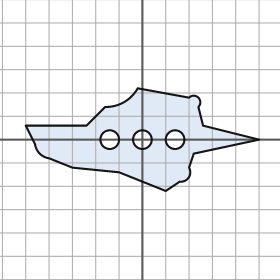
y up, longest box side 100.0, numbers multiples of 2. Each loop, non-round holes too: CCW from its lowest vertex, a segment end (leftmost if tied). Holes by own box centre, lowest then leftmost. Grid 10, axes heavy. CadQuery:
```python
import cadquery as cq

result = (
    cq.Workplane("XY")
    .moveTo(10.0, -22.0)
    .lineTo(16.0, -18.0)
    .threePointArc((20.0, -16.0), (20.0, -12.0))
    .lineTo(22.0, -6.0)
    .lineTo(50.0, 0.0)
    .lineTo(26.0, 6.0)
    .lineTo(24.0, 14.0)
    .threePointArc((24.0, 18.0), (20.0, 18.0))
    .lineTo(-2.0, 22.0)
    .threePointArc((-8.0, 16.0), (-16.0, 14.0))
    .lineTo(-24.0, 6.0)
    .lineTo(-50.0, 6.0)
    .lineTo(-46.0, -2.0)
    .threePointArc((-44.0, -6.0), (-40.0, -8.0))
    .lineTo(-30.0, -12.0)
    .lineTo(-10.0, -14.0)
    .close()
    .moveTo(-14.0, 0.0)
    .circle(4.0)
    .moveTo(0.0, 0.0)
    .circle(4.0)
    .moveTo(14.0, 0.0)
    .circle(4.0)
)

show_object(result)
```